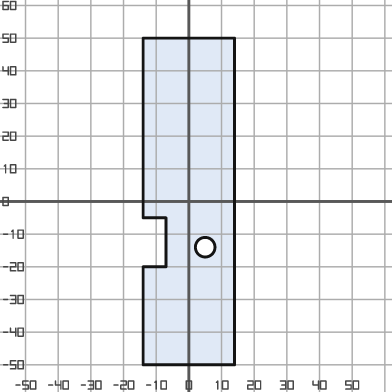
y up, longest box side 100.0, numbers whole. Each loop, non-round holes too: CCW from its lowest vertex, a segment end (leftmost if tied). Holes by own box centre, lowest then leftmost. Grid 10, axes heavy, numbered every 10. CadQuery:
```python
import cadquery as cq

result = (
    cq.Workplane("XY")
    .moveTo(-14.0, -50.0)
    .lineTo(14.0, -50.0)
    .lineTo(14.0, 50.0)
    .lineTo(-14.0, 50.0)
    .lineTo(-14.0, -5.0)
    .lineTo(-7.0, -5.0)
    .lineTo(-7.0, -20.0)
    .lineTo(-14.0, -20.0)
    .close()
    .moveTo(5.0, -14.0)
    .circle(3.0)
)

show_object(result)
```